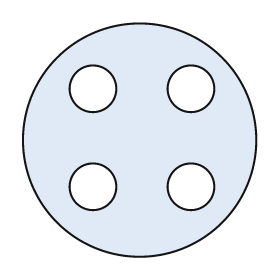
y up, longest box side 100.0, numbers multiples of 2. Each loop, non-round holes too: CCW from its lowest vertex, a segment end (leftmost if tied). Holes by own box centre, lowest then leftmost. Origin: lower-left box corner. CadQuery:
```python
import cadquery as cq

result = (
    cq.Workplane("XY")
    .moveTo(50.0, 50.0)
    .circle(50.0)
    .moveTo(30.0, 30.0)
    .circle(10.0)
    .moveTo(72.0, 30.0)
    .circle(10.0)
    .moveTo(30.0, 72.0)
    .circle(10.0)
    .moveTo(72.0, 72.0)
    .circle(10.0)
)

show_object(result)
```